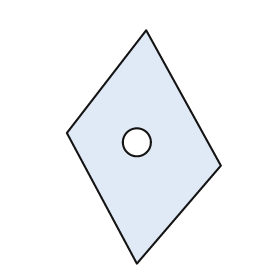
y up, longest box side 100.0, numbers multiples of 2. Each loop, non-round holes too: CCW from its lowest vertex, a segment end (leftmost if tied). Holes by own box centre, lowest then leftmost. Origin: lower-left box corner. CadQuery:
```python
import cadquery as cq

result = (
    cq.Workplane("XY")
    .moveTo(30.0, 0.0)
    .lineTo(66.0, 42.0)
    .lineTo(34.0, 100.0)
    .lineTo(0.0, 56.0)
    .close()
    .moveTo(30.0, 52.0)
    .circle(6.0)
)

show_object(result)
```